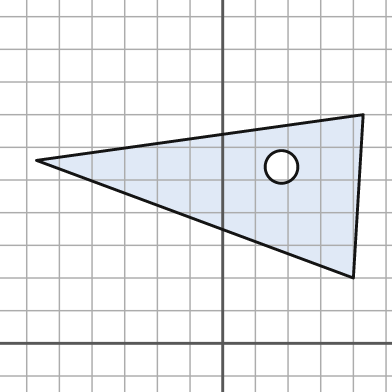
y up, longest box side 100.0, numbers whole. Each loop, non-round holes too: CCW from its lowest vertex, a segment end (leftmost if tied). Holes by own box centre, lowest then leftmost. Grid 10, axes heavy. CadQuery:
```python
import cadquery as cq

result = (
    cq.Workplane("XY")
    .moveTo(40.0, 20.0)
    .lineTo(43.0, 70.0)
    .lineTo(-57.0, 56.0)
    .close()
    .moveTo(18.0, 54.0)
    .circle(5.0)
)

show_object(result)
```